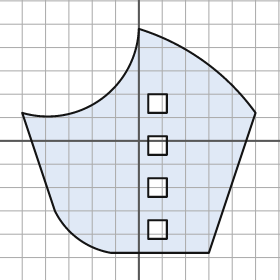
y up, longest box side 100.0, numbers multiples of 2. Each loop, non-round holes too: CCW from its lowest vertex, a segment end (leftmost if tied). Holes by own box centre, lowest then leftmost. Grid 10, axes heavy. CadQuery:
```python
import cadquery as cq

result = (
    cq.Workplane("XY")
    .moveTo(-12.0, -48.0)
    .lineTo(30.0, -48.0)
    .lineTo(50.0, 12.0)
    .threePointArc((28.0, 34.0), (0.0, 48.0))
    .threePointArc((-16.0, 18.0), (-50.0, 12.0))
    .lineTo(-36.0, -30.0)
    .threePointArc((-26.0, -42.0), (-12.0, -48.0))
    .close()
    .moveTo(4.0, -42.0)
    .lineTo(12.0, -42.0)
    .lineTo(12.0, -34.0)
    .lineTo(4.0, -34.0)
    .close()
    .moveTo(4.0, -24.0)
    .lineTo(12.0, -24.0)
    .lineTo(12.0, -16.0)
    .lineTo(4.0, -16.0)
    .close()
    .moveTo(4.0, -6.0)
    .lineTo(12.0, -6.0)
    .lineTo(12.0, 2.0)
    .lineTo(4.0, 2.0)
    .close()
    .moveTo(4.0, 12.0)
    .lineTo(12.0, 12.0)
    .lineTo(12.0, 20.0)
    .lineTo(4.0, 20.0)
    .close()
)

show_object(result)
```